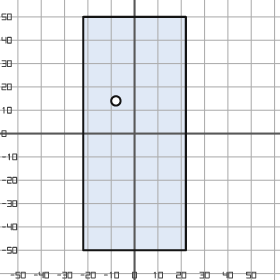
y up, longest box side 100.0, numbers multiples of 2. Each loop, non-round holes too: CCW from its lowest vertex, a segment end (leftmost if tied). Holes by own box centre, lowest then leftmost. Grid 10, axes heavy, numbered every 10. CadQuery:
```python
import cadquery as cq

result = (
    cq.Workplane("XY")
    .moveTo(-22.0, -50.0)
    .lineTo(22.0, -50.0)
    .lineTo(22.0, 50.0)
    .lineTo(-22.0, 50.0)
    .close()
    .moveTo(-8.0, 14.0)
    .circle(2.0)
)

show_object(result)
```